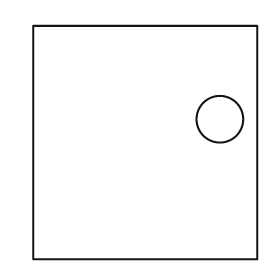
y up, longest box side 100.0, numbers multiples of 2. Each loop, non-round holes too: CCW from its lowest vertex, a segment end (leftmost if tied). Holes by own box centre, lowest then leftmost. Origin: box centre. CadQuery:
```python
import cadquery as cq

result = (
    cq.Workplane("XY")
    .moveTo(-48.0, -50.0)
    .lineTo(48.0, -50.0)
    .lineTo(48.0, 50.0)
    .lineTo(-48.0, 50.0)
    .close()
    .moveTo(32.0, 10.0)
    .circle(10.0)
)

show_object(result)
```